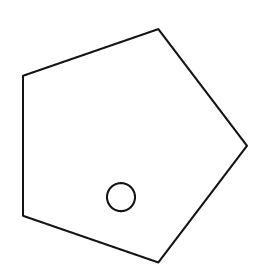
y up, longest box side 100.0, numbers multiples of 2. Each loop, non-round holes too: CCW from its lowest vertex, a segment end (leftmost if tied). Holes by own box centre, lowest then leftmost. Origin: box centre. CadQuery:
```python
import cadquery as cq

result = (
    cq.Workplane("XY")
    .moveTo(10.0, -50.0)
    .lineTo(48.0, 0.0)
    .lineTo(10.0, 50.0)
    .lineTo(-48.0, 30.0)
    .lineTo(-48.0, -30.0)
    .close()
    .moveTo(-6.0, -22.0)
    .circle(6.0)
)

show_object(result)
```